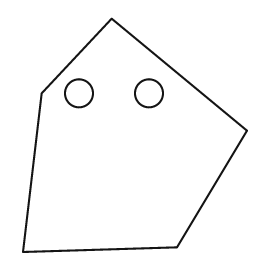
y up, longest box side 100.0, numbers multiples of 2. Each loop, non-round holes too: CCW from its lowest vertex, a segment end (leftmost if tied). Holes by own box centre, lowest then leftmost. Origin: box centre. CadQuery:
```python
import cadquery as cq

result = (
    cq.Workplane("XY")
    .moveTo(-48.0, -50.0)
    .lineTo(18.0, -48.0)
    .lineTo(48.0, 2.0)
    .lineTo(-10.0, 50.0)
    .lineTo(-40.0, 18.0)
    .close()
    .moveTo(-24.0, 18.0)
    .circle(6.0)
    .moveTo(6.0, 18.0)
    .circle(6.0)
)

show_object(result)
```